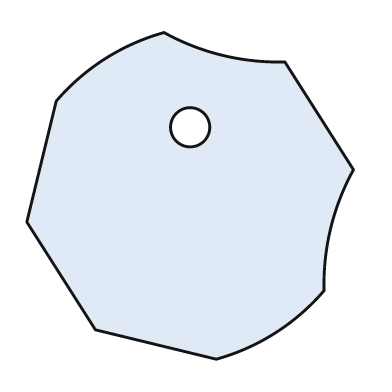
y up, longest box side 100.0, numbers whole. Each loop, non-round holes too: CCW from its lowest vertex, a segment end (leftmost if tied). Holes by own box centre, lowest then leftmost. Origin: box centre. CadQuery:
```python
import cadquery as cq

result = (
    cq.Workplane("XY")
    .moveTo(8.0, -50.0)
    .threePointArc((26.0, -42.0), (41.0, -29.0))
    .threePointArc((43.0, -10.0), (50.0, 8.0))
    .lineTo(29.0, 41.0)
    .threePointArc((10.0, 43.0), (-8.0, 50.0))
    .threePointArc((-26.0, 42.0), (-41.0, 29.0))
    .lineTo(-50.0, -8.0)
    .lineTo(-29.0, -41.0)
    .close()
    .moveTo(0.0, 21.0)
    .circle(6.0)
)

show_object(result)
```